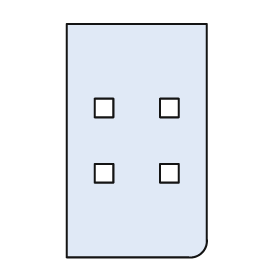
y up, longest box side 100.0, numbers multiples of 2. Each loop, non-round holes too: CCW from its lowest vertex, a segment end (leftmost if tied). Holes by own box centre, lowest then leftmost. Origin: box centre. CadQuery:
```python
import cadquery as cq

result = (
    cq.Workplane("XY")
    .moveTo(-30.0, -50.0)
    .lineTo(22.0, -50.0)
    .threePointArc((28.0, -48.0), (30.0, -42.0))
    .lineTo(30.0, 50.0)
    .lineTo(-30.0, 50.0)
    .close()
    .moveTo(-18.0, -18.0)
    .lineTo(-10.0, -18.0)
    .lineTo(-10.0, -10.0)
    .lineTo(-18.0, -10.0)
    .close()
    .moveTo(10.0, -18.0)
    .lineTo(18.0, -18.0)
    .lineTo(18.0, -10.0)
    .lineTo(10.0, -10.0)
    .close()
    .moveTo(-18.0, 10.0)
    .lineTo(-10.0, 10.0)
    .lineTo(-10.0, 18.0)
    .lineTo(-18.0, 18.0)
    .close()
    .moveTo(10.0, 10.0)
    .lineTo(18.0, 10.0)
    .lineTo(18.0, 18.0)
    .lineTo(10.0, 18.0)
    .close()
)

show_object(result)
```